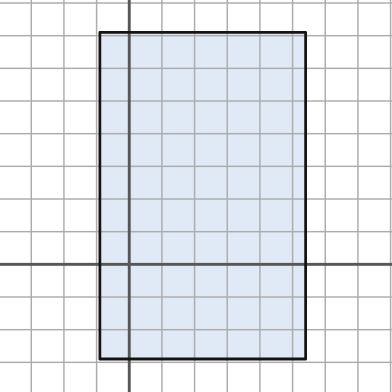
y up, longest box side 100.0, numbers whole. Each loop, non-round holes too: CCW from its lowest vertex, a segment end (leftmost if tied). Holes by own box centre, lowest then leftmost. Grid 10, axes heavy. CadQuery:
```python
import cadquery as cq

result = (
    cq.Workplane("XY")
    .moveTo(-9.0, -29.0)
    .lineTo(54.0, -29.0)
    .lineTo(54.0, 71.0)
    .lineTo(-9.0, 71.0)
    .close()
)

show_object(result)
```